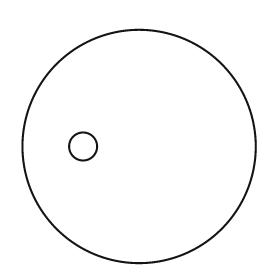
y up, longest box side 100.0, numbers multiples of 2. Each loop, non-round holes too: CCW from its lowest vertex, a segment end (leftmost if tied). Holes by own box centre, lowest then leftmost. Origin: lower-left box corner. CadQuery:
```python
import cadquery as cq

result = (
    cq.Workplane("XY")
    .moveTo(50.0, 50.0)
    .circle(50.0)
    .moveTo(26.0, 50.0)
    .circle(6.0)
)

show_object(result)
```